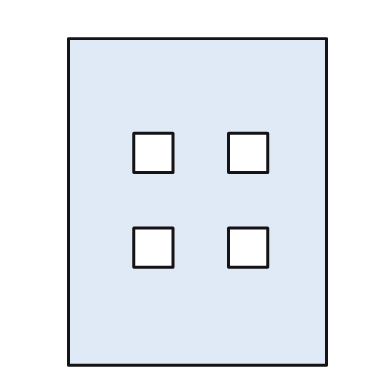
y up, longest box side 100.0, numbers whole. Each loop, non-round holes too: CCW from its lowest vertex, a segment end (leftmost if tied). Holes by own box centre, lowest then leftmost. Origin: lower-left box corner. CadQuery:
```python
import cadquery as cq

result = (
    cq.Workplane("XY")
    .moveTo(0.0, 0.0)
    .lineTo(79.0, 0.0)
    .lineTo(79.0, 100.0)
    .lineTo(0.0, 100.0)
    .close()
    .moveTo(20.0, 30.0)
    .lineTo(32.0, 30.0)
    .lineTo(32.0, 42.0)
    .lineTo(20.0, 42.0)
    .close()
    .moveTo(49.0, 30.0)
    .lineTo(61.0, 30.0)
    .lineTo(61.0, 42.0)
    .lineTo(49.0, 42.0)
    .close()
    .moveTo(20.0, 59.0)
    .lineTo(32.0, 59.0)
    .lineTo(32.0, 71.0)
    .lineTo(20.0, 71.0)
    .close()
    .moveTo(49.0, 59.0)
    .lineTo(61.0, 59.0)
    .lineTo(61.0, 71.0)
    .lineTo(49.0, 71.0)
    .close()
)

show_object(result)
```